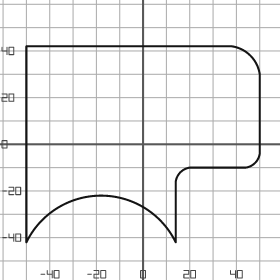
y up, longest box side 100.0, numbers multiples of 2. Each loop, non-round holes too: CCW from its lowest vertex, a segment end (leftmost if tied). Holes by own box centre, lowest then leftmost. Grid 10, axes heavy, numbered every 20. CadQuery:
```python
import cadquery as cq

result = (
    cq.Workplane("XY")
    .moveTo(-50.0, -42.0)
    .threePointArc((-18.0, -22.0), (14.0, -42.0))
    .lineTo(14.0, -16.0)
    .threePointArc((16.0, -12.0), (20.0, -10.0))
    .lineTo(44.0, -10.0)
    .threePointArc((48.0, -8.0), (50.0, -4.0))
    .lineTo(50.0, 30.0)
    .threePointArc((46.0, 38.0), (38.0, 42.0))
    .lineTo(-50.0, 42.0)
    .close()
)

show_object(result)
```